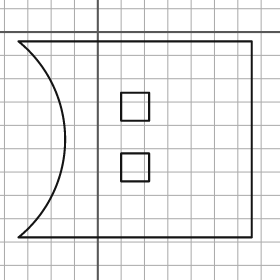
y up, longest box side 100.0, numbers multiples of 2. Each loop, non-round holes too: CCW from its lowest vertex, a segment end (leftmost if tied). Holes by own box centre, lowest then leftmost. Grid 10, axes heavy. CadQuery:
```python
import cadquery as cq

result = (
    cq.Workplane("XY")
    .moveTo(-34.0, -88.0)
    .lineTo(66.0, -88.0)
    .lineTo(66.0, -4.0)
    .lineTo(-34.0, -4.0)
    .threePointArc((-14.0, -46.0), (-34.0, -88.0))
    .close()
    .moveTo(10.0, -64.0)
    .lineTo(22.0, -64.0)
    .lineTo(22.0, -52.0)
    .lineTo(10.0, -52.0)
    .close()
    .moveTo(10.0, -38.0)
    .lineTo(22.0, -38.0)
    .lineTo(22.0, -26.0)
    .lineTo(10.0, -26.0)
    .close()
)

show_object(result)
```